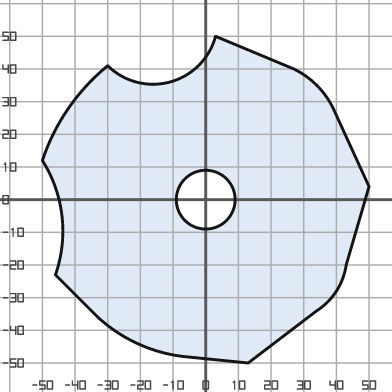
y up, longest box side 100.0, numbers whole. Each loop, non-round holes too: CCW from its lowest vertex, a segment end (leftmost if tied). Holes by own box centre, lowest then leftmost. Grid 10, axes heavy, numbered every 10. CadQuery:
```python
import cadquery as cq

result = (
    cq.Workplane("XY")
    .moveTo(13.0, -50.0)
    .lineTo(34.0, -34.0)
    .threePointArc((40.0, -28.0), (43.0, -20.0))
    .lineTo(50.0, 4.0)
    .lineTo(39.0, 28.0)
    .threePointArc((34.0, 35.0), (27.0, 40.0))
    .lineTo(3.0, 50.0)
    .threePointArc((-11.0, 36.0), (-30.0, 41.0))
    .threePointArc((-42.0, 28.0), (-50.0, 12.0))
    .threePointArc((-44.0, -5.0), (-46.0, -23.0))
    .lineTo(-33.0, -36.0)
    .threePointArc((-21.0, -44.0), (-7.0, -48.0))
    .close()
    .moveTo(0.0, 0.0)
    .circle(9.0)
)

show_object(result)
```